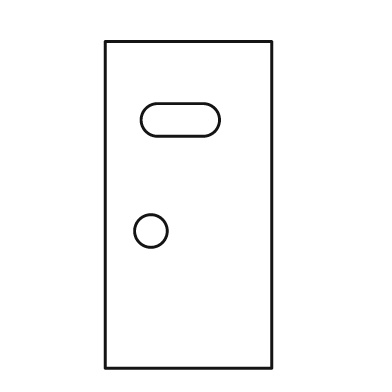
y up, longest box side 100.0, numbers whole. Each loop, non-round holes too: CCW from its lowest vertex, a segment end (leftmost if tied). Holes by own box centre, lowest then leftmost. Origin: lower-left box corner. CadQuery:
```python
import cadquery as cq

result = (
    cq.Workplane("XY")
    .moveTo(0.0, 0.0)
    .lineTo(51.0, 0.0)
    .lineTo(51.0, 100.0)
    .lineTo(0.0, 100.0)
    .close()
    .moveTo(14.0, 42.0)
    .circle(5.0)
    .moveTo(16.0, 71.0)
    .lineTo(30.0, 71.0)
    .threePointArc((35.0, 76.0), (30.0, 81.0))
    .lineTo(16.0, 81.0)
    .threePointArc((11.0, 76.0), (16.0, 71.0))
    .close()
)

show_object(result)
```